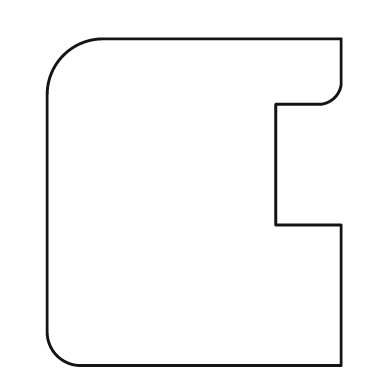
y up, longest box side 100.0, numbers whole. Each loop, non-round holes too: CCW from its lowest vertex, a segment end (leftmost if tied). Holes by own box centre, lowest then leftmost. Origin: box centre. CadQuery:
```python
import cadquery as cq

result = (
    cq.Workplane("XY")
    .moveTo(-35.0, -50.0)
    .lineTo(45.0, -50.0)
    .lineTo(45.0, -7.0)
    .lineTo(25.0, -7.0)
    .lineTo(25.0, 30.0)
    .lineTo(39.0, 30.0)
    .threePointArc((43.0, 32.0), (45.0, 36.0))
    .lineTo(45.0, 50.0)
    .lineTo(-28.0, 50.0)
    .threePointArc((-40.0, 45.0), (-45.0, 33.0))
    .lineTo(-45.0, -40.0)
    .threePointArc((-42.0, -47.0), (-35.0, -50.0))
    .close()
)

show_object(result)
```